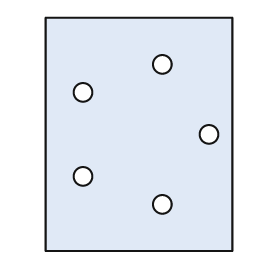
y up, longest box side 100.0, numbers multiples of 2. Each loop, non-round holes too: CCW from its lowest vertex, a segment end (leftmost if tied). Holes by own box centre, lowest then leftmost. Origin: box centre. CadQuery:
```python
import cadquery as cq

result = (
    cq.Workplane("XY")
    .moveTo(-40.0, -50.0)
    .lineTo(40.0, -50.0)
    .lineTo(40.0, 50.0)
    .lineTo(-40.0, 50.0)
    .close()
    .moveTo(10.0, -30.0)
    .circle(4.0)
    .moveTo(-24.0, -18.0)
    .circle(4.0)
    .moveTo(30.0, 0.0)
    .circle(4.0)
    .moveTo(-24.0, 18.0)
    .circle(4.0)
    .moveTo(10.0, 30.0)
    .circle(4.0)
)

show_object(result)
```